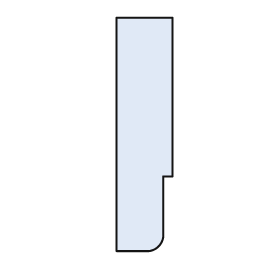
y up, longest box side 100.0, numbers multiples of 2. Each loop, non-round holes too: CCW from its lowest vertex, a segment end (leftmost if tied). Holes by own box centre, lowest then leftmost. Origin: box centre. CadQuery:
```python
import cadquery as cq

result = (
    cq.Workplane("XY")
    .moveTo(-12.0, -50.0)
    .lineTo(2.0, -50.0)
    .threePointArc((6.0, -48.0), (8.0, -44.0))
    .lineTo(8.0, -18.0)
    .lineTo(12.0, -18.0)
    .lineTo(12.0, 50.0)
    .lineTo(-12.0, 50.0)
    .close()
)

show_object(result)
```